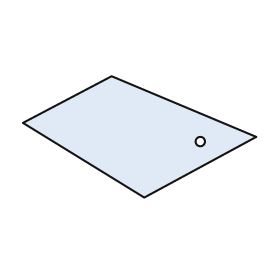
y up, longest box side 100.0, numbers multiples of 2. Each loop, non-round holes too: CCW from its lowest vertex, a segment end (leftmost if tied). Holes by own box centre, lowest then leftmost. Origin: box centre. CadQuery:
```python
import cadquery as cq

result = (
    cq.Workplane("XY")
    .moveTo(2.0, -26.0)
    .lineTo(50.0, 0.0)
    .lineTo(-12.0, 26.0)
    .lineTo(-50.0, 6.0)
    .close()
    .moveTo(26.0, -2.0)
    .circle(2.0)
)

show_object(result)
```